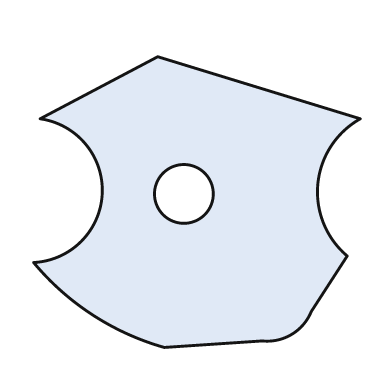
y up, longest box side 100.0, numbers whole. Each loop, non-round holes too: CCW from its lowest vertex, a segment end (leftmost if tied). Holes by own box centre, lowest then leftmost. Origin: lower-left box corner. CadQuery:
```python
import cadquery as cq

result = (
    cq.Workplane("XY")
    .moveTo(40.0, 0.0)
    .lineTo(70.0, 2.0)
    .threePointArc((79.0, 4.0), (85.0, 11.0))
    .lineTo(96.0, 28.0)
    .threePointArc((87.0, 50.0), (100.0, 70.0))
    .lineTo(38.0, 89.0)
    .lineTo(2.0, 70.0)
    .threePointArc((21.0, 47.0), (0.0, 26.0))
    .threePointArc((18.0, 10.0), (40.0, 0.0))
    .close()
    .moveTo(46.0, 47.0)
    .circle(9.0)
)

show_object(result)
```